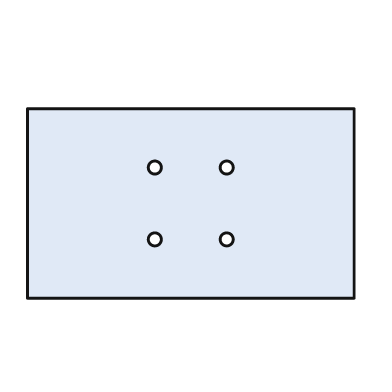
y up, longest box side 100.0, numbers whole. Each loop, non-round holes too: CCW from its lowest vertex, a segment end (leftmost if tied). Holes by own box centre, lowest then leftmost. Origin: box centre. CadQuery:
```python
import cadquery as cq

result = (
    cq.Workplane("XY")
    .moveTo(-50.0, -29.0)
    .lineTo(50.0, -29.0)
    .lineTo(50.0, 29.0)
    .lineTo(-50.0, 29.0)
    .close()
    .moveTo(-11.0, -11.0)
    .circle(2.0)
    .moveTo(11.0, -11.0)
    .circle(2.0)
    .moveTo(-11.0, 11.0)
    .circle(2.0)
    .moveTo(11.0, 11.0)
    .circle(2.0)
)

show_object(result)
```